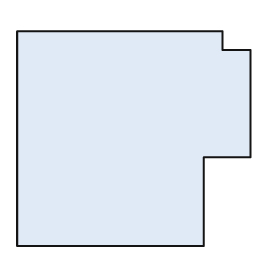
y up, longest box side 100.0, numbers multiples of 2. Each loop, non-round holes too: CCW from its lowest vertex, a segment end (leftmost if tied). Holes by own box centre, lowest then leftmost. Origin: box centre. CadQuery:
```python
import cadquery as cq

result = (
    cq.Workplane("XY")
    .moveTo(-50.0, -46.0)
    .lineTo(30.0, -46.0)
    .lineTo(30.0, -8.0)
    .lineTo(50.0, -8.0)
    .lineTo(50.0, 38.0)
    .lineTo(38.0, 38.0)
    .lineTo(38.0, 46.0)
    .lineTo(-50.0, 46.0)
    .close()
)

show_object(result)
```